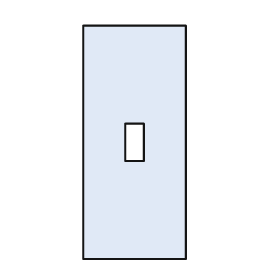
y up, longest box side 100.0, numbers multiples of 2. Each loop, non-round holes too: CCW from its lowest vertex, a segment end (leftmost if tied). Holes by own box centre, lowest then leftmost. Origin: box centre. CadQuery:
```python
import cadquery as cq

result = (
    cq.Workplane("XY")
    .moveTo(-22.0, -50.0)
    .lineTo(22.0, -50.0)
    .lineTo(22.0, 50.0)
    .lineTo(-22.0, 50.0)
    .close()
    .moveTo(-4.0, -8.0)
    .lineTo(4.0, -8.0)
    .lineTo(4.0, 8.0)
    .lineTo(-4.0, 8.0)
    .close()
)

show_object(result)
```